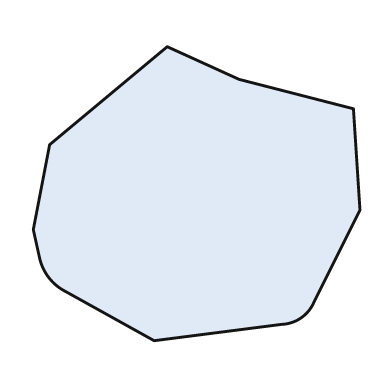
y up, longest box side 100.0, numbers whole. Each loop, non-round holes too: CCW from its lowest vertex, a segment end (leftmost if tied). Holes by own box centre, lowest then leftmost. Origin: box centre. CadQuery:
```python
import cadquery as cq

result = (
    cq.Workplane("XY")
    .moveTo(-13.0, -45.0)
    .lineTo(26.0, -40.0)
    .threePointArc((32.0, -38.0), (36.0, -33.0))
    .lineTo(50.0, -5.0)
    .lineTo(48.0, 26.0)
    .lineTo(13.0, 35.0)
    .lineTo(-9.0, 45.0)
    .lineTo(-45.0, 15.0)
    .lineTo(-50.0, -11.0)
    .lineTo(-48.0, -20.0)
    .threePointArc((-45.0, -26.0), (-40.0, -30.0))
    .close()
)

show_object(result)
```